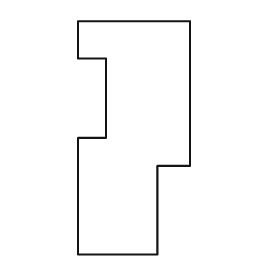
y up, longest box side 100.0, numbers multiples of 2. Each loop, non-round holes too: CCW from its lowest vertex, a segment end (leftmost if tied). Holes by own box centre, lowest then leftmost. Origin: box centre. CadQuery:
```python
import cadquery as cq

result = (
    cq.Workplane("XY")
    .moveTo(-24.0, -50.0)
    .lineTo(10.0, -50.0)
    .lineTo(10.0, -12.0)
    .lineTo(24.0, -12.0)
    .lineTo(24.0, 50.0)
    .lineTo(-24.0, 50.0)
    .lineTo(-24.0, 34.0)
    .lineTo(-12.0, 34.0)
    .lineTo(-12.0, 0.0)
    .lineTo(-24.0, 0.0)
    .close()
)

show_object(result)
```